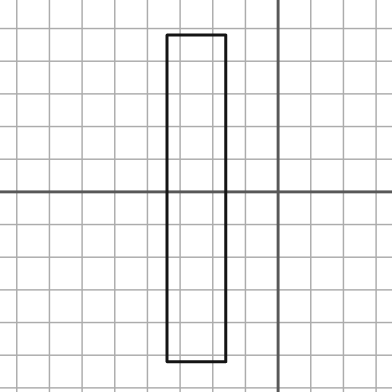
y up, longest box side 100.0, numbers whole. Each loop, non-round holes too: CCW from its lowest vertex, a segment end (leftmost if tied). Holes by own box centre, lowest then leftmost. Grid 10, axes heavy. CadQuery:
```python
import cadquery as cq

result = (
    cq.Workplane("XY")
    .moveTo(-34.0, -52.0)
    .lineTo(-16.0, -52.0)
    .lineTo(-16.0, 48.0)
    .lineTo(-34.0, 48.0)
    .close()
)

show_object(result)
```